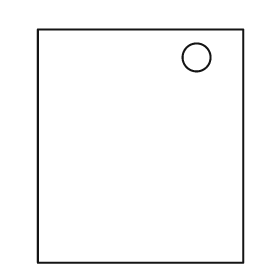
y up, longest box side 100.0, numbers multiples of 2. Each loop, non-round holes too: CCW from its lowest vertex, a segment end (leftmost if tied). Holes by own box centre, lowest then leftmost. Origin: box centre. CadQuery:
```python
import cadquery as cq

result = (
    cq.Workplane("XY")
    .moveTo(-44.0, -50.0)
    .lineTo(44.0, -50.0)
    .lineTo(44.0, 50.0)
    .lineTo(-44.0, 50.0)
    .close()
    .moveTo(24.0, 38.0)
    .circle(6.0)
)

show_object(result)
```